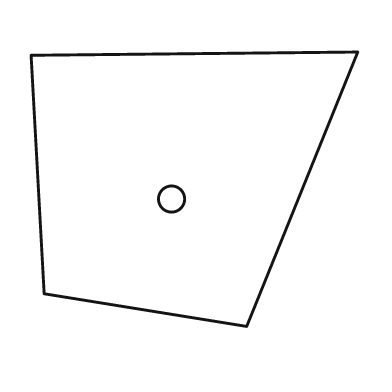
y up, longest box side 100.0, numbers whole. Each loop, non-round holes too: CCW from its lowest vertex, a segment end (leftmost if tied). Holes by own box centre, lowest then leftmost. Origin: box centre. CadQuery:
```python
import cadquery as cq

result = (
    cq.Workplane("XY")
    .moveTo(16.0, -42.0)
    .lineTo(50.0, 42.0)
    .lineTo(-50.0, 41.0)
    .lineTo(-46.0, -32.0)
    .close()
    .moveTo(-7.0, -3.0)
    .circle(4.0)
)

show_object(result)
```